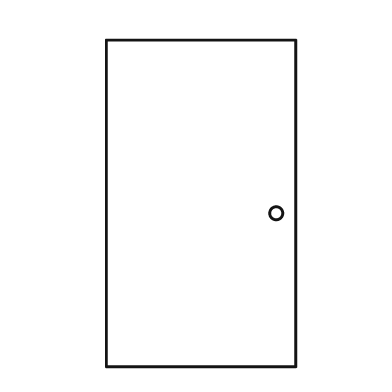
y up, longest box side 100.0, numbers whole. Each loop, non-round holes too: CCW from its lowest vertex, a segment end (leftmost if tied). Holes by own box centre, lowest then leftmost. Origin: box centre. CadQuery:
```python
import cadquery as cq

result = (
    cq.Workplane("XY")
    .moveTo(-29.0, -50.0)
    .lineTo(29.0, -50.0)
    .lineTo(29.0, 50.0)
    .lineTo(-29.0, 50.0)
    .close()
    .moveTo(23.0, -3.0)
    .circle(2.0)
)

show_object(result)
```